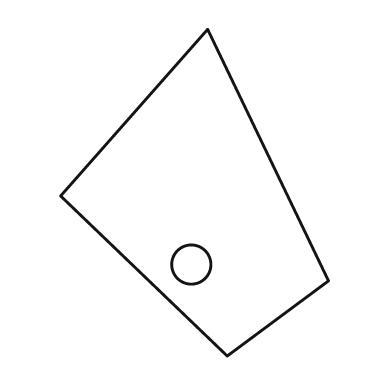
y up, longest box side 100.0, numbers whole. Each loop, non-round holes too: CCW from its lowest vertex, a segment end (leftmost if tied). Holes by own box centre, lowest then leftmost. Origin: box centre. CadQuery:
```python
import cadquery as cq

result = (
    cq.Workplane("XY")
    .moveTo(10.0, -50.0)
    .lineTo(41.0, -27.0)
    .lineTo(4.0, 50.0)
    .lineTo(-41.0, -1.0)
    .close()
    .moveTo(-1.0, -22.0)
    .circle(6.0)
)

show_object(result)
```